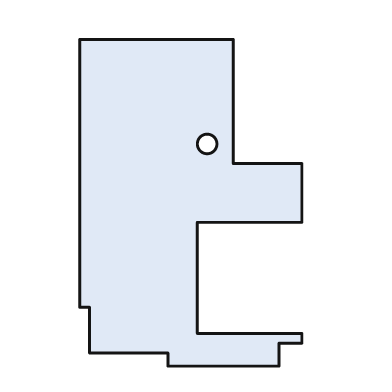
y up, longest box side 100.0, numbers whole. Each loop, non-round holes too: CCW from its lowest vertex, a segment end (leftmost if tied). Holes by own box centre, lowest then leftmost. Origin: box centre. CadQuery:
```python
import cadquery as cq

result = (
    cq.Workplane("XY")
    .moveTo(-7.0, -50.0)
    .lineTo(27.0, -50.0)
    .lineTo(27.0, -43.0)
    .lineTo(34.0, -43.0)
    .lineTo(34.0, -40.0)
    .lineTo(2.0, -40.0)
    .lineTo(2.0, -6.0)
    .lineTo(34.0, -6.0)
    .lineTo(34.0, 12.0)
    .lineTo(13.0, 12.0)
    .lineTo(13.0, 50.0)
    .lineTo(-34.0, 50.0)
    .lineTo(-34.0, -32.0)
    .lineTo(-31.0, -32.0)
    .lineTo(-31.0, -46.0)
    .lineTo(-7.0, -46.0)
    .close()
    .moveTo(5.0, 18.0)
    .circle(3.0)
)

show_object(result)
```